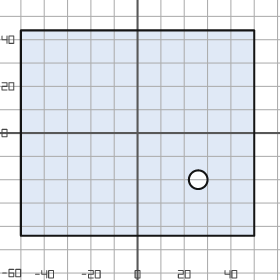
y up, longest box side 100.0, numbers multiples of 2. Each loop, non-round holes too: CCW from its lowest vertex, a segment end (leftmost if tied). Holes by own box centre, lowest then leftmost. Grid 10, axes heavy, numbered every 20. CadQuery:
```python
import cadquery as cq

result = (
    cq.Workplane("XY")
    .moveTo(-50.0, -44.0)
    .lineTo(50.0, -44.0)
    .lineTo(50.0, 44.0)
    .lineTo(-50.0, 44.0)
    .close()
    .moveTo(26.0, -20.0)
    .circle(4.0)
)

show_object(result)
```